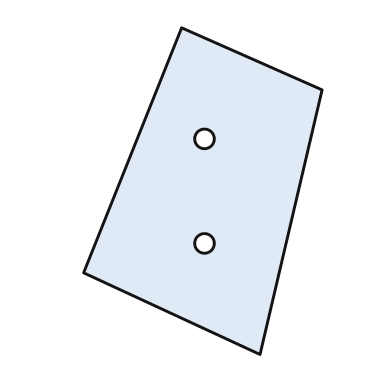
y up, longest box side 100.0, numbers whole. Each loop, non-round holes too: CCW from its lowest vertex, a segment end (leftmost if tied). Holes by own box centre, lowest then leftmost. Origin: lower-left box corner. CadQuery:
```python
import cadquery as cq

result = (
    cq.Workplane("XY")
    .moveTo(54.0, 0.0)
    .lineTo(73.0, 81.0)
    .lineTo(30.0, 100.0)
    .lineTo(0.0, 25.0)
    .close()
    .moveTo(37.0, 34.0)
    .circle(3.0)
    .moveTo(37.0, 66.0)
    .circle(3.0)
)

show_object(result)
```